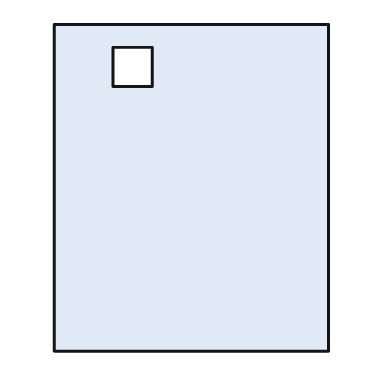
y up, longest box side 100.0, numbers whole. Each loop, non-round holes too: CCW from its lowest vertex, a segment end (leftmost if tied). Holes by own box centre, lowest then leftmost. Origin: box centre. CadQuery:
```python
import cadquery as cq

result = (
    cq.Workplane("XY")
    .moveTo(-42.0, -50.0)
    .lineTo(42.0, -50.0)
    .lineTo(42.0, 50.0)
    .lineTo(-42.0, 50.0)
    .close()
    .moveTo(-24.0, 31.0)
    .lineTo(-12.0, 31.0)
    .lineTo(-12.0, 43.0)
    .lineTo(-24.0, 43.0)
    .close()
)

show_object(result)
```